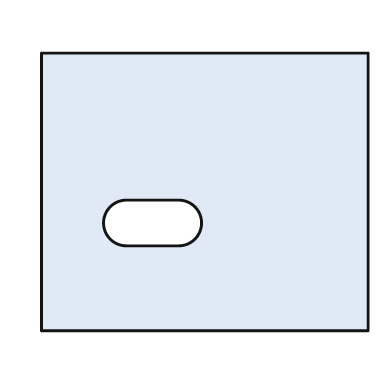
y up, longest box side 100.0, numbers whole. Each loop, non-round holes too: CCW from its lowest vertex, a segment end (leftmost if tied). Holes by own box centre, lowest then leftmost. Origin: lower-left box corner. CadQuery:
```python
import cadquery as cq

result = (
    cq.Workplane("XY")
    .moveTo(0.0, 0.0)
    .lineTo(100.0, 0.0)
    .lineTo(100.0, 85.0)
    .lineTo(0.0, 85.0)
    .close()
    .moveTo(26.0, 26.0)
    .lineTo(42.0, 26.0)
    .threePointArc((49.0, 33.0), (42.0, 40.0))
    .lineTo(26.0, 40.0)
    .threePointArc((19.0, 33.0), (26.0, 26.0))
    .close()
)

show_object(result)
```